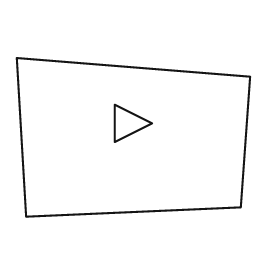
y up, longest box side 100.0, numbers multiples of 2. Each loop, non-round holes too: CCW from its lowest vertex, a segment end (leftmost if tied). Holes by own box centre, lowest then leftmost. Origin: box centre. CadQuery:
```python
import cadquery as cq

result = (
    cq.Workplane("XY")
    .moveTo(-46.0, -34.0)
    .lineTo(46.0, -30.0)
    .lineTo(50.0, 26.0)
    .lineTo(-50.0, 34.0)
    .close()
    .moveTo(-8.0, -2.0)
    .lineTo(8.0, 6.0)
    .lineTo(-8.0, 14.0)
    .close()
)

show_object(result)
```